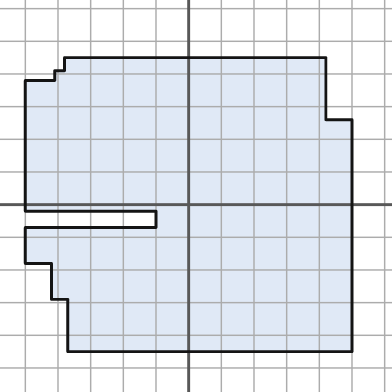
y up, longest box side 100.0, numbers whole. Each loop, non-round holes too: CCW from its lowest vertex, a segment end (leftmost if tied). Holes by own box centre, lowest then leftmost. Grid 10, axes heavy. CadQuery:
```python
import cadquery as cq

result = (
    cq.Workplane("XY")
    .moveTo(-37.0, -45.0)
    .lineTo(50.0, -45.0)
    .lineTo(50.0, 26.0)
    .lineTo(42.0, 26.0)
    .lineTo(42.0, 45.0)
    .lineTo(-38.0, 45.0)
    .lineTo(-38.0, 41.0)
    .lineTo(-41.0, 41.0)
    .lineTo(-41.0, 38.0)
    .lineTo(-50.0, 38.0)
    .lineTo(-50.0, -2.0)
    .lineTo(-10.0, -2.0)
    .lineTo(-10.0, -7.0)
    .lineTo(-50.0, -7.0)
    .lineTo(-50.0, -18.0)
    .lineTo(-42.0, -18.0)
    .lineTo(-42.0, -29.0)
    .lineTo(-37.0, -29.0)
    .close()
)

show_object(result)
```